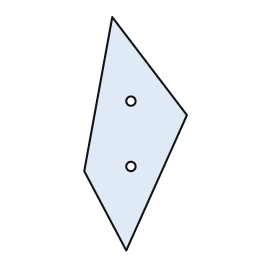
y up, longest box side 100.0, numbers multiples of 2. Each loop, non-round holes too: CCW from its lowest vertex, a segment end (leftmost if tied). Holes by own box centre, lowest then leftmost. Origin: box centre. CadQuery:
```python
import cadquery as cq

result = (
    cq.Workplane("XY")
    .moveTo(-4.0, -50.0)
    .lineTo(22.0, 8.0)
    .lineTo(-10.0, 50.0)
    .lineTo(-22.0, -16.0)
    .close()
    .moveTo(-2.0, -14.0)
    .circle(2.0)
    .moveTo(-2.0, 14.0)
    .circle(2.0)
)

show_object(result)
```